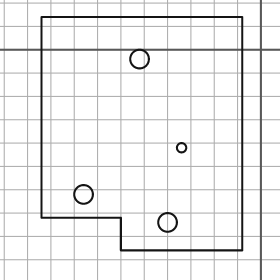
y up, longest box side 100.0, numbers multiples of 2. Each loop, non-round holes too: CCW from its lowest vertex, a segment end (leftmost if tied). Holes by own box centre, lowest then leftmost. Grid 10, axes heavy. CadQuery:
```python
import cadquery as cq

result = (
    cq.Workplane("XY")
    .moveTo(-60.0, -86.0)
    .lineTo(-8.0, -86.0)
    .lineTo(-8.0, 14.0)
    .lineTo(-94.0, 14.0)
    .lineTo(-94.0, -72.0)
    .lineTo(-60.0, -72.0)
    .close()
    .moveTo(-40.0, -74.0)
    .circle(4.0)
    .moveTo(-76.0, -62.0)
    .circle(4.0)
    .moveTo(-34.0, -42.0)
    .circle(2.0)
    .moveTo(-52.0, -4.0)
    .circle(4.0)
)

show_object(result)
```